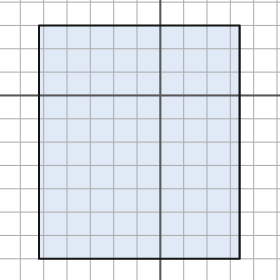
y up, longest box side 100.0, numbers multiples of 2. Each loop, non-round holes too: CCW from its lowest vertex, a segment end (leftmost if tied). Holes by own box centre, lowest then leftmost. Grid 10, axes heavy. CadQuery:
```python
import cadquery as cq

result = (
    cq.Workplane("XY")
    .moveTo(-52.0, -70.0)
    .lineTo(34.0, -70.0)
    .lineTo(34.0, 30.0)
    .lineTo(-52.0, 30.0)
    .close()
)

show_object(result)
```